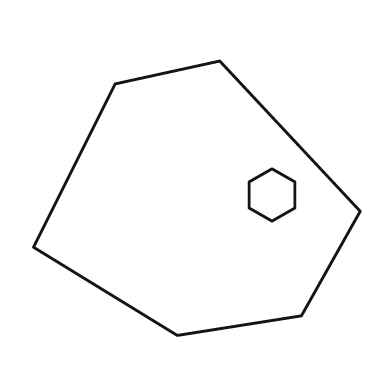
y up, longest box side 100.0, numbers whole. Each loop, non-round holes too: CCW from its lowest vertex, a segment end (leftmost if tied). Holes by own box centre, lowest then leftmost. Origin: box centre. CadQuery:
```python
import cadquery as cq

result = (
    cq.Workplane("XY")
    .moveTo(-6.0, -42.0)
    .lineTo(32.0, -36.0)
    .lineTo(50.0, -4.0)
    .lineTo(7.0, 42.0)
    .lineTo(-25.0, 35.0)
    .lineTo(-50.0, -15.0)
    .close()
    .moveTo(23.0, -7.0)
    .lineTo(30.0, -3.0)
    .lineTo(30.0, 5.0)
    .lineTo(23.0, 9.0)
    .lineTo(16.0, 5.0)
    .lineTo(16.0, -3.0)
    .close()
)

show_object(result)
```